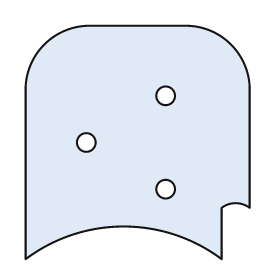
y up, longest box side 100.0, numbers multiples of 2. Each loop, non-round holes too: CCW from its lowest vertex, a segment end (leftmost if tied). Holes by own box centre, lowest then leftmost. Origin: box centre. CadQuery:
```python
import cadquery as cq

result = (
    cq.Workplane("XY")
    .moveTo(-48.0, -50.0)
    .threePointArc((-6.0, -36.0), (36.0, -50.0))
    .lineTo(36.0, -28.0)
    .threePointArc((42.0, -26.0), (48.0, -28.0))
    .lineTo(48.0, 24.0)
    .threePointArc((40.0, 42.0), (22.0, 50.0))
    .lineTo(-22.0, 50.0)
    .threePointArc((-40.0, 42.0), (-48.0, 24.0))
    .close()
    .moveTo(12.0, -20.0)
    .circle(4.0)
    .moveTo(-22.0, 0.0)
    .circle(4.0)
    .moveTo(12.0, 20.0)
    .circle(4.0)
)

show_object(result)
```